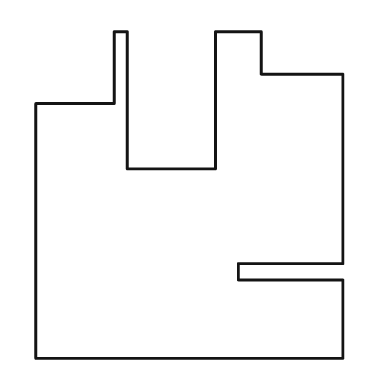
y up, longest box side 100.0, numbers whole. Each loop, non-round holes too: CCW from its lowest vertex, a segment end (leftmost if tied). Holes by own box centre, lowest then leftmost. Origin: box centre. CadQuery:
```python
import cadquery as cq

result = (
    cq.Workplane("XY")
    .moveTo(-47.0, -50.0)
    .lineTo(47.0, -50.0)
    .lineTo(47.0, -26.0)
    .lineTo(15.0, -26.0)
    .lineTo(15.0, -21.0)
    .lineTo(47.0, -21.0)
    .lineTo(47.0, 37.0)
    .lineTo(22.0, 37.0)
    .lineTo(22.0, 50.0)
    .lineTo(8.0, 50.0)
    .lineTo(8.0, 8.0)
    .lineTo(-19.0, 8.0)
    .lineTo(-19.0, 50.0)
    .lineTo(-23.0, 50.0)
    .lineTo(-23.0, 28.0)
    .lineTo(-47.0, 28.0)
    .close()
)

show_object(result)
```